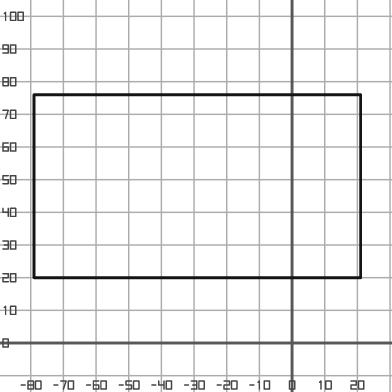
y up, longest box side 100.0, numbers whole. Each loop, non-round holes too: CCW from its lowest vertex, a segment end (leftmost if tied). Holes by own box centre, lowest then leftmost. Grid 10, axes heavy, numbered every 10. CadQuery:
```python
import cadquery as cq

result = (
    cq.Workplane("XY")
    .moveTo(-79.0, 20.0)
    .lineTo(21.0, 20.0)
    .lineTo(21.0, 76.0)
    .lineTo(-79.0, 76.0)
    .close()
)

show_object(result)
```